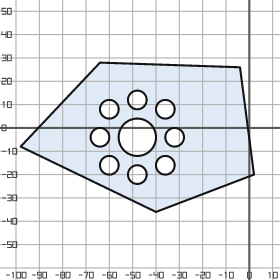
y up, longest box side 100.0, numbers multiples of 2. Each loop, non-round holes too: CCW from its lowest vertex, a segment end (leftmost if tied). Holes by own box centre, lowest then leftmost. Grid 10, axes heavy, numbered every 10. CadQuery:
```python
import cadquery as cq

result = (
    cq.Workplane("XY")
    .moveTo(-40.0, -36.0)
    .lineTo(2.0, -20.0)
    .lineTo(-4.0, 26.0)
    .lineTo(-64.0, 28.0)
    .lineTo(-98.0, -8.0)
    .close()
    .moveTo(-48.0, -20.0)
    .circle(4.0)
    .moveTo(-60.0, -16.0)
    .circle(4.0)
    .moveTo(-36.0, -16.0)
    .circle(4.0)
    .moveTo(-64.0, -4.0)
    .circle(4.0)
    .moveTo(-48.0, -4.0)
    .circle(8.0)
    .moveTo(-32.0, -4.0)
    .circle(4.0)
    .moveTo(-60.0, 8.0)
    .circle(4.0)
    .moveTo(-36.0, 8.0)
    .circle(4.0)
    .moveTo(-48.0, 12.0)
    .circle(4.0)
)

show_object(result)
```